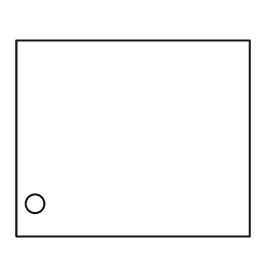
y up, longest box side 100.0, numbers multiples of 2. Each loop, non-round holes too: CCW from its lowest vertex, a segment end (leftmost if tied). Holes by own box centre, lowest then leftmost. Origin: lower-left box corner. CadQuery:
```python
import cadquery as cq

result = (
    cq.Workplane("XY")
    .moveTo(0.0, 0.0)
    .lineTo(100.0, 0.0)
    .lineTo(100.0, 84.0)
    .lineTo(0.0, 84.0)
    .close()
    .moveTo(8.0, 14.0)
    .circle(4.0)
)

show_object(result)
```